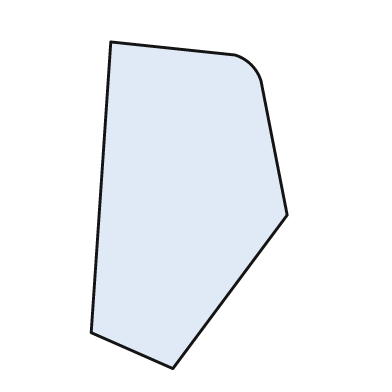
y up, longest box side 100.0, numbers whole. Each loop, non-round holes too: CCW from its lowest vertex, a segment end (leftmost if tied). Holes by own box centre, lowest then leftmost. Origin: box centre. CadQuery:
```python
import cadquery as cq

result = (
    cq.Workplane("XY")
    .moveTo(-5.0, -50.0)
    .lineTo(30.0, -3.0)
    .lineTo(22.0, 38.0)
    .threePointArc((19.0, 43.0), (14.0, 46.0))
    .lineTo(-24.0, 50.0)
    .lineTo(-30.0, -39.0)
    .close()
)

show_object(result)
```